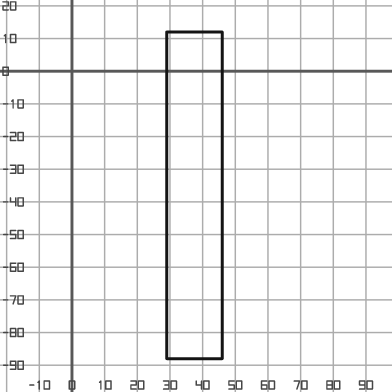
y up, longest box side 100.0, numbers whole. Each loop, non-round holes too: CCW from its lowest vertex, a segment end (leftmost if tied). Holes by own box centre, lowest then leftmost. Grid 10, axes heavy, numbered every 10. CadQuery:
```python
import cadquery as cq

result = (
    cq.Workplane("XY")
    .moveTo(29.0, -88.0)
    .lineTo(46.0, -88.0)
    .lineTo(46.0, 12.0)
    .lineTo(29.0, 12.0)
    .close()
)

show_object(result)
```